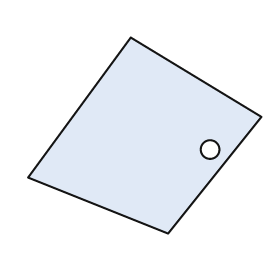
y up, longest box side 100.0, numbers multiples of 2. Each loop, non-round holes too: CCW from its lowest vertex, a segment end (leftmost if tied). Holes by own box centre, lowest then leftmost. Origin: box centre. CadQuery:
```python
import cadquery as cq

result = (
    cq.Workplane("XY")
    .moveTo(10.0, -42.0)
    .lineTo(50.0, 8.0)
    .lineTo(-6.0, 42.0)
    .lineTo(-50.0, -18.0)
    .close()
    .moveTo(28.0, -6.0)
    .circle(4.0)
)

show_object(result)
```